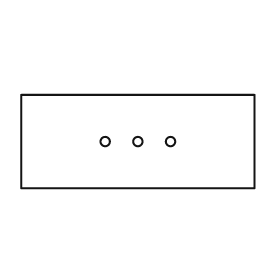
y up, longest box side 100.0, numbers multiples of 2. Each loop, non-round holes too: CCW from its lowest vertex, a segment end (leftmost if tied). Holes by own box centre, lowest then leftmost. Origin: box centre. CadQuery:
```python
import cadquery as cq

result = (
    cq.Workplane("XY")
    .moveTo(-50.0, -20.0)
    .lineTo(50.0, -20.0)
    .lineTo(50.0, 20.0)
    .lineTo(-50.0, 20.0)
    .close()
    .moveTo(-14.0, 0.0)
    .circle(2.0)
    .moveTo(0.0, 0.0)
    .circle(2.0)
    .moveTo(14.0, 0.0)
    .circle(2.0)
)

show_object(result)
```